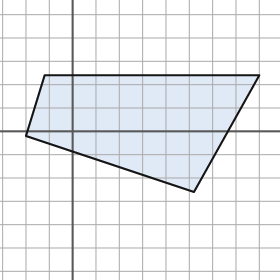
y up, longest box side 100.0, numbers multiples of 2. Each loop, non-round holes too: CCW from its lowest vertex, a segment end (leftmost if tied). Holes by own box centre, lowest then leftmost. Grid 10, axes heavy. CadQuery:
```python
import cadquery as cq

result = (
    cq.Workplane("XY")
    .moveTo(52.0, -26.0)
    .lineTo(80.0, 24.0)
    .lineTo(-12.0, 24.0)
    .lineTo(-20.0, -2.0)
    .close()
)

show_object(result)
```